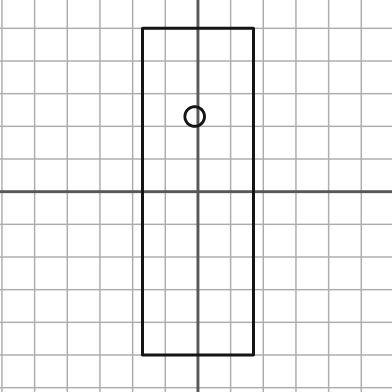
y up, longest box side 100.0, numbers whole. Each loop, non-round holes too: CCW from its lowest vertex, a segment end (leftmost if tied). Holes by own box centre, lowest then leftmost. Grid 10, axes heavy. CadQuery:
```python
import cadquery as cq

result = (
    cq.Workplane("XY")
    .moveTo(-17.0, -50.0)
    .lineTo(17.0, -50.0)
    .lineTo(17.0, 50.0)
    .lineTo(-17.0, 50.0)
    .close()
    .moveTo(-1.0, 23.0)
    .circle(3.0)
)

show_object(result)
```